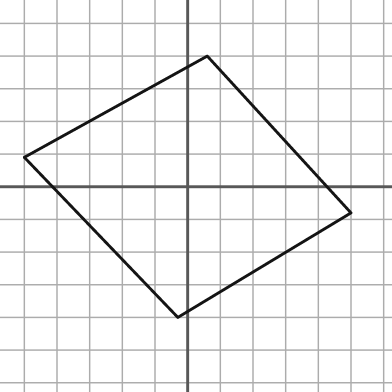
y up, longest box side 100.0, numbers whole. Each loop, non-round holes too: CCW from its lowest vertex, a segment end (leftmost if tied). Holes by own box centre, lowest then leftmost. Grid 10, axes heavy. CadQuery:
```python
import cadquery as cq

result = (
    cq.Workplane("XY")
    .moveTo(-3.0, -40.0)
    .lineTo(50.0, -8.0)
    .lineTo(6.0, 40.0)
    .lineTo(-50.0, 9.0)
    .close()
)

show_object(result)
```